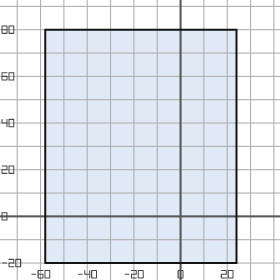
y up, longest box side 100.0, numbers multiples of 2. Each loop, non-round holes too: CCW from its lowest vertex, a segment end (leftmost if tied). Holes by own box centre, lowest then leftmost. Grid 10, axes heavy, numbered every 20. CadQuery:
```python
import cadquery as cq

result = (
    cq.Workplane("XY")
    .moveTo(-58.0, -20.0)
    .lineTo(24.0, -20.0)
    .lineTo(24.0, 80.0)
    .lineTo(-58.0, 80.0)
    .close()
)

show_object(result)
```